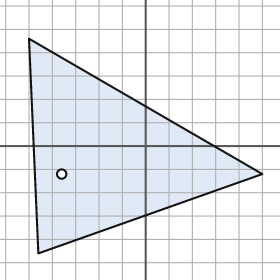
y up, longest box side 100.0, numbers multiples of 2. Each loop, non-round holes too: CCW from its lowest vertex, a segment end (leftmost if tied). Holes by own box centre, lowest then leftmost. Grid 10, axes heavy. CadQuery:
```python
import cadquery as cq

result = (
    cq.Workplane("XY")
    .moveTo(-46.0, -46.0)
    .lineTo(50.0, -12.0)
    .lineTo(-50.0, 46.0)
    .close()
    .moveTo(-36.0, -12.0)
    .circle(2.0)
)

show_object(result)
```